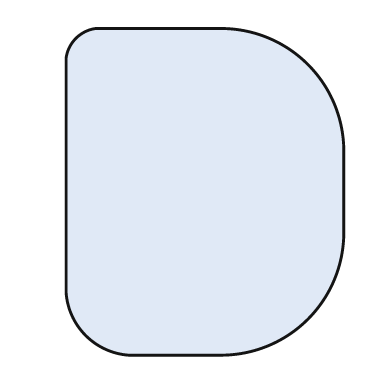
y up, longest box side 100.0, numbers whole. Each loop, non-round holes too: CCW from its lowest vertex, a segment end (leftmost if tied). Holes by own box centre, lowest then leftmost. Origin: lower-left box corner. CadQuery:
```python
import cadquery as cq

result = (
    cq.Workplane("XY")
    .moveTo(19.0, 0.0)
    .lineTo(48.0, 0.0)
    .threePointArc((74.0, 11.0), (85.0, 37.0))
    .lineTo(85.0, 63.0)
    .threePointArc((74.0, 89.0), (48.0, 100.0))
    .lineTo(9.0, 100.0)
    .threePointArc((3.0, 97.0), (0.0, 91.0))
    .lineTo(0.0, 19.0)
    .threePointArc((6.0, 6.0), (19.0, 0.0))
    .close()
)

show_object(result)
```